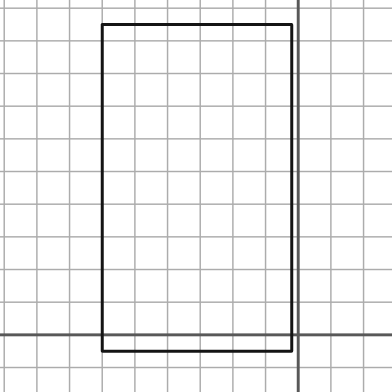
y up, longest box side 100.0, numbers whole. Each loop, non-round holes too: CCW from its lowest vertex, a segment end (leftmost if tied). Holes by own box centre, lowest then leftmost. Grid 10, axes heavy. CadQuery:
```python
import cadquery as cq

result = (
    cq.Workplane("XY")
    .moveTo(-60.0, -5.0)
    .lineTo(-2.0, -5.0)
    .lineTo(-2.0, 95.0)
    .lineTo(-60.0, 95.0)
    .close()
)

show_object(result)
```